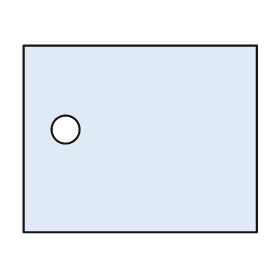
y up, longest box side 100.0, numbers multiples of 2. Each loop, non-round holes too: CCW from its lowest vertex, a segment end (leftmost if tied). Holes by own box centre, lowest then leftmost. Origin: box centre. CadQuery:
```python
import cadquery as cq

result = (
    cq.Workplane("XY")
    .moveTo(-50.0, -40.0)
    .lineTo(50.0, -40.0)
    .lineTo(50.0, 40.0)
    .lineTo(-50.0, 40.0)
    .close()
    .moveTo(-32.0, 4.0)
    .circle(6.0)
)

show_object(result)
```